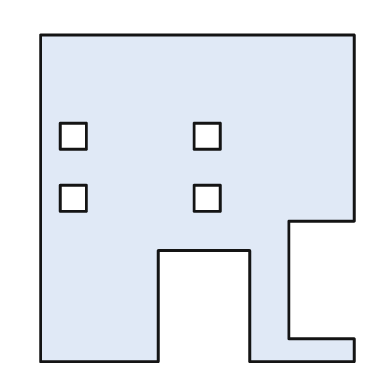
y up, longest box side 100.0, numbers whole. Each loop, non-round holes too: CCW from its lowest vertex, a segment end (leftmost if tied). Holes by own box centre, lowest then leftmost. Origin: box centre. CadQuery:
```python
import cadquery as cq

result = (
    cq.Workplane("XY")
    .moveTo(-48.0, -50.0)
    .lineTo(-12.0, -50.0)
    .lineTo(-12.0, -16.0)
    .lineTo(16.0, -16.0)
    .lineTo(16.0, -50.0)
    .lineTo(48.0, -50.0)
    .lineTo(48.0, -43.0)
    .lineTo(28.0, -43.0)
    .lineTo(28.0, -7.0)
    .lineTo(48.0, -7.0)
    .lineTo(48.0, 50.0)
    .lineTo(-48.0, 50.0)
    .close()
    .moveTo(-42.0, -4.0)
    .lineTo(-34.0, -4.0)
    .lineTo(-34.0, 4.0)
    .lineTo(-42.0, 4.0)
    .close()
    .moveTo(-1.0, -4.0)
    .lineTo(7.0, -4.0)
    .lineTo(7.0, 4.0)
    .lineTo(-1.0, 4.0)
    .close()
    .moveTo(-42.0, 15.0)
    .lineTo(-34.0, 15.0)
    .lineTo(-34.0, 23.0)
    .lineTo(-42.0, 23.0)
    .close()
    .moveTo(-1.0, 15.0)
    .lineTo(7.0, 15.0)
    .lineTo(7.0, 23.0)
    .lineTo(-1.0, 23.0)
    .close()
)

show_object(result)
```